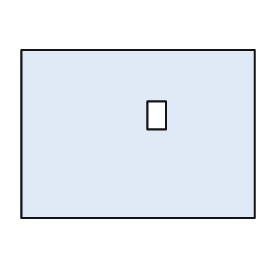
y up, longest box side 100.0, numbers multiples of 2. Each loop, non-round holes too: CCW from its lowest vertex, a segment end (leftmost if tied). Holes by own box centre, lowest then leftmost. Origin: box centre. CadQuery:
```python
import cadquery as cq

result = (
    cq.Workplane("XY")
    .moveTo(-50.0, -36.0)
    .lineTo(50.0, -36.0)
    .lineTo(50.0, 36.0)
    .lineTo(-50.0, 36.0)
    .close()
    .moveTo(4.0, 2.0)
    .lineTo(12.0, 2.0)
    .lineTo(12.0, 14.0)
    .lineTo(4.0, 14.0)
    .close()
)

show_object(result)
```